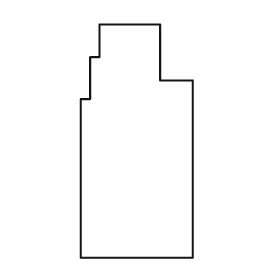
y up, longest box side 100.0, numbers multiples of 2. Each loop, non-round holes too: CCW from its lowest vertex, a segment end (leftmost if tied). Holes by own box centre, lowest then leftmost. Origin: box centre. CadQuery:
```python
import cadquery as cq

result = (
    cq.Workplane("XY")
    .moveTo(-24.0, -50.0)
    .lineTo(24.0, -50.0)
    .lineTo(24.0, 26.0)
    .lineTo(10.0, 26.0)
    .lineTo(10.0, 50.0)
    .lineTo(-16.0, 50.0)
    .lineTo(-16.0, 36.0)
    .lineTo(-20.0, 36.0)
    .lineTo(-20.0, 18.0)
    .lineTo(-24.0, 18.0)
    .close()
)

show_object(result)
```